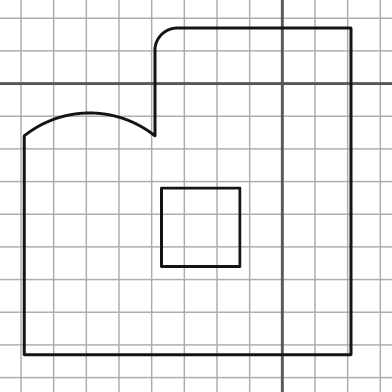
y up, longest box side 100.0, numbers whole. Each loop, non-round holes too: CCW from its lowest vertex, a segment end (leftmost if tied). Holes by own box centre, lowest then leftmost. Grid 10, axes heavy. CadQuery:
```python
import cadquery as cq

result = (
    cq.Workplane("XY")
    .moveTo(-79.0, -83.0)
    .lineTo(21.0, -83.0)
    .lineTo(21.0, 17.0)
    .lineTo(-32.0, 17.0)
    .threePointArc((-37.0, 15.0), (-39.0, 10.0))
    .lineTo(-39.0, -16.0)
    .threePointArc((-59.0, -9.0), (-79.0, -16.0))
    .close()
    .moveTo(-37.0, -56.0)
    .lineTo(-13.0, -56.0)
    .lineTo(-13.0, -32.0)
    .lineTo(-37.0, -32.0)
    .close()
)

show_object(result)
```